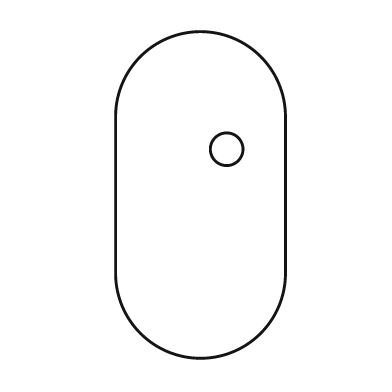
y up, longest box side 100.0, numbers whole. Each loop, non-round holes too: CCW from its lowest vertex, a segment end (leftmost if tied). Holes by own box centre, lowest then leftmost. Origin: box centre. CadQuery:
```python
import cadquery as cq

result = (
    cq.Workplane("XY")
    .moveTo(-26.0, -24.0)
    .threePointArc((0.0, -50.0), (26.0, -24.0))
    .lineTo(26.0, 24.0)
    .threePointArc((0.0, 50.0), (-26.0, 24.0))
    .close()
    .moveTo(8.0, 14.0)
    .circle(5.0)
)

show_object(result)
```